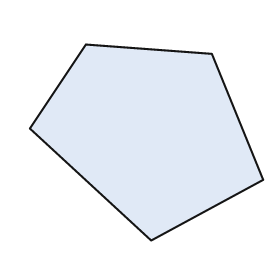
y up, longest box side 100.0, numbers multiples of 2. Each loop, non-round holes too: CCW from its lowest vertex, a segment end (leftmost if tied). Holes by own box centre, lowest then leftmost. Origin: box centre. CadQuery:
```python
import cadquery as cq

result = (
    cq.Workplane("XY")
    .moveTo(2.0, -42.0)
    .lineTo(50.0, -16.0)
    .lineTo(28.0, 38.0)
    .lineTo(-26.0, 42.0)
    .lineTo(-50.0, 6.0)
    .close()
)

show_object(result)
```